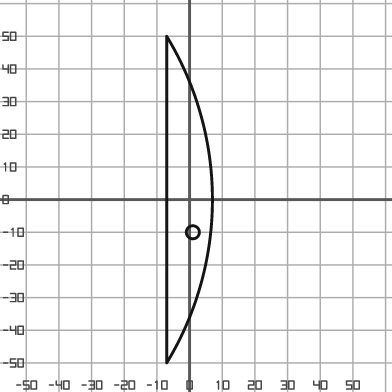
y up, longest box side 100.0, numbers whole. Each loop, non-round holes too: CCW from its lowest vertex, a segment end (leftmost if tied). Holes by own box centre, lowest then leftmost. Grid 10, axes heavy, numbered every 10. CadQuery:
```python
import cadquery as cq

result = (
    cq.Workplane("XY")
    .moveTo(-7.0, -50.0)
    .threePointArc((7.0, 0.0), (-7.0, 50.0))
    .close()
    .moveTo(1.0, -10.0)
    .circle(2.0)
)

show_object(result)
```